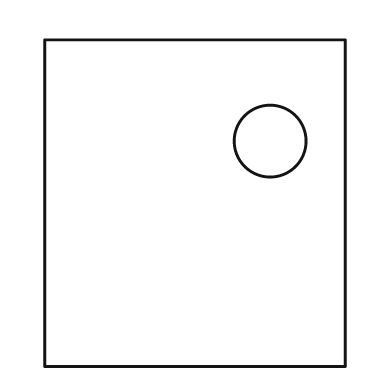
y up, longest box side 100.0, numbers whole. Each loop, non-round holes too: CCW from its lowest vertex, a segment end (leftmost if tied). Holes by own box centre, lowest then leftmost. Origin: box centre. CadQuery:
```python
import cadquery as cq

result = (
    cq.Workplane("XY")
    .moveTo(-46.0, -50.0)
    .lineTo(46.0, -50.0)
    .lineTo(46.0, 50.0)
    .lineTo(-46.0, 50.0)
    .close()
    .moveTo(23.0, 19.0)
    .circle(11.0)
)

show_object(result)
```